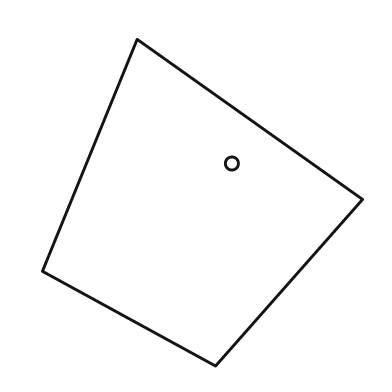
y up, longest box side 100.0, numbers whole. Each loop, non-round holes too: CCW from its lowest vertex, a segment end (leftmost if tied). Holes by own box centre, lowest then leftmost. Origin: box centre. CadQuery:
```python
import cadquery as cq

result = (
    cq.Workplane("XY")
    .moveTo(4.0, -50.0)
    .lineTo(49.0, 1.0)
    .lineTo(-20.0, 50.0)
    .lineTo(-49.0, -21.0)
    .close()
    .moveTo(9.0, 12.0)
    .circle(2.0)
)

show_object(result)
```